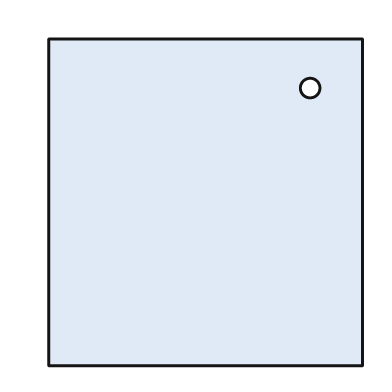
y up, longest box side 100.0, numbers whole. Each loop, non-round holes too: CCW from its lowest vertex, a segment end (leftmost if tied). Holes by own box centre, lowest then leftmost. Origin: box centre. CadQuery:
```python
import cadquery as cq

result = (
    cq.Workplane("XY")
    .moveTo(-48.0, -50.0)
    .lineTo(48.0, -50.0)
    .lineTo(48.0, 50.0)
    .lineTo(-48.0, 50.0)
    .close()
    .moveTo(32.0, 35.0)
    .circle(3.0)
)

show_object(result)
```